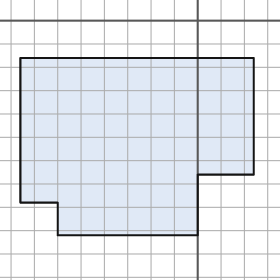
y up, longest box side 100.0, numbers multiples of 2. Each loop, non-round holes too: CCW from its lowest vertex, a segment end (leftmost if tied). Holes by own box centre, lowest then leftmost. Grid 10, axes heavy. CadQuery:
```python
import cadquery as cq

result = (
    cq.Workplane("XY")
    .moveTo(-60.0, -92.0)
    .lineTo(0.0, -92.0)
    .lineTo(0.0, -66.0)
    .lineTo(24.0, -66.0)
    .lineTo(24.0, -16.0)
    .lineTo(-76.0, -16.0)
    .lineTo(-76.0, -78.0)
    .lineTo(-60.0, -78.0)
    .close()
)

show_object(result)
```